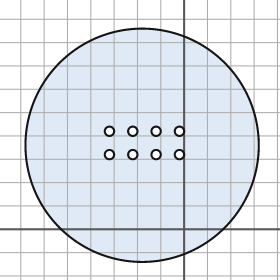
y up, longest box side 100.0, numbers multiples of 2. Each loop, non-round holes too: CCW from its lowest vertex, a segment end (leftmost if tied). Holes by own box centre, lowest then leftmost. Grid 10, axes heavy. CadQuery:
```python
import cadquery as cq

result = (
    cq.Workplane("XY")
    .moveTo(-18.0, 36.0)
    .circle(50.0)
    .moveTo(-32.0, 32.0)
    .circle(2.0)
    .moveTo(-22.0, 32.0)
    .circle(2.0)
    .moveTo(-12.0, 32.0)
    .circle(2.0)
    .moveTo(-2.0, 32.0)
    .circle(2.0)
    .moveTo(-32.0, 42.0)
    .circle(2.0)
    .moveTo(-22.0, 42.0)
    .circle(2.0)
    .moveTo(-12.0, 42.0)
    .circle(2.0)
    .moveTo(-2.0, 42.0)
    .circle(2.0)
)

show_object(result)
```